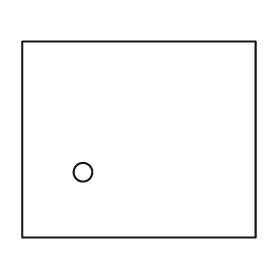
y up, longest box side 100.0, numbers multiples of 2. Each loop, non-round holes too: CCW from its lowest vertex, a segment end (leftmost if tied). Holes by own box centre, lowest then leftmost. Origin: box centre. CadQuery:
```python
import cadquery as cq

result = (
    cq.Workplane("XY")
    .moveTo(-50.0, -42.0)
    .lineTo(50.0, -42.0)
    .lineTo(50.0, 42.0)
    .lineTo(-50.0, 42.0)
    .close()
    .moveTo(-24.0, -14.0)
    .circle(4.0)
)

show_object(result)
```